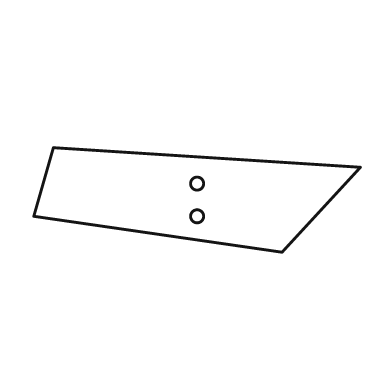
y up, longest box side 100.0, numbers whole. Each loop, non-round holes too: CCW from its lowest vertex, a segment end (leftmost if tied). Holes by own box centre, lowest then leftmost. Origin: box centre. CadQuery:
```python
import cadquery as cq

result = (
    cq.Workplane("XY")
    .moveTo(26.0, -16.0)
    .lineTo(50.0, 10.0)
    .lineTo(-44.0, 16.0)
    .lineTo(-50.0, -5.0)
    .close()
    .moveTo(0.0, -5.0)
    .circle(2.0)
    .moveTo(0.0, 5.0)
    .circle(2.0)
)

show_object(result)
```